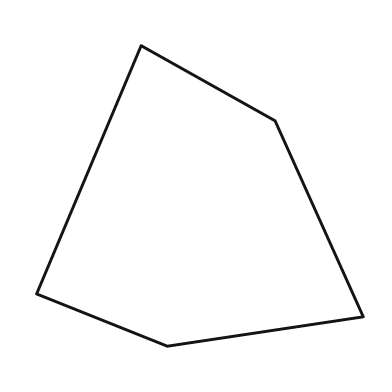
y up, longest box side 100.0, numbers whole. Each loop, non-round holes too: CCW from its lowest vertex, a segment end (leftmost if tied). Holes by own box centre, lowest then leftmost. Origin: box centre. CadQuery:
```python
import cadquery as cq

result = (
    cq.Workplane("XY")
    .moveTo(-10.0, -46.0)
    .lineTo(50.0, -37.0)
    .lineTo(23.0, 23.0)
    .lineTo(-18.0, 46.0)
    .lineTo(-50.0, -30.0)
    .close()
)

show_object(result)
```